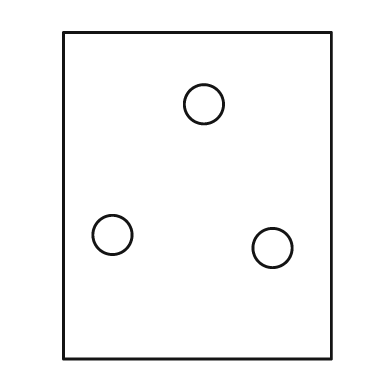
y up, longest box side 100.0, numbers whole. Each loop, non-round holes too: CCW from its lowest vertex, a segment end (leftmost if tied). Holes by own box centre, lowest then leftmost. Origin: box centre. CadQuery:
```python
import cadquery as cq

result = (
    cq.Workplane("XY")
    .moveTo(-41.0, -50.0)
    .lineTo(41.0, -50.0)
    .lineTo(41.0, 50.0)
    .lineTo(-41.0, 50.0)
    .close()
    .moveTo(23.0, -16.0)
    .circle(6.0)
    .moveTo(-26.0, -12.0)
    .circle(6.0)
    .moveTo(2.0, 28.0)
    .circle(6.0)
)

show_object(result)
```